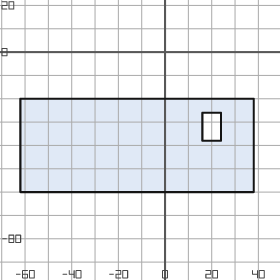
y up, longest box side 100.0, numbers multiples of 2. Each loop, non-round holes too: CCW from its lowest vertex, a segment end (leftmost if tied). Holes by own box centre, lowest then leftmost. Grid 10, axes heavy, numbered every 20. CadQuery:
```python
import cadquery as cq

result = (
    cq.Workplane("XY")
    .moveTo(-62.0, -60.0)
    .lineTo(38.0, -60.0)
    .lineTo(38.0, -20.0)
    .lineTo(-62.0, -20.0)
    .close()
    .moveTo(16.0, -38.0)
    .lineTo(24.0, -38.0)
    .lineTo(24.0, -26.0)
    .lineTo(16.0, -26.0)
    .close()
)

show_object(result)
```